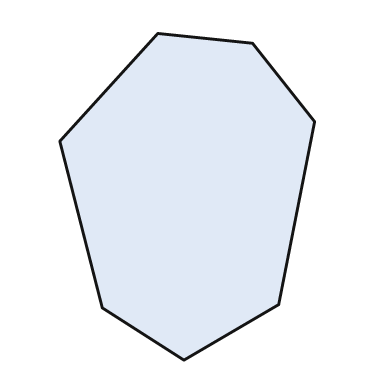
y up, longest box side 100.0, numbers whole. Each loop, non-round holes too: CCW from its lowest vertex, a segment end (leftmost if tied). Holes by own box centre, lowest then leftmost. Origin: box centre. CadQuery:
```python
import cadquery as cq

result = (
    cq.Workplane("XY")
    .moveTo(-1.0, -50.0)
    .lineTo(28.0, -33.0)
    .lineTo(39.0, 23.0)
    .lineTo(20.0, 47.0)
    .lineTo(-9.0, 50.0)
    .lineTo(-39.0, 17.0)
    .lineTo(-26.0, -34.0)
    .close()
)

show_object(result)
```